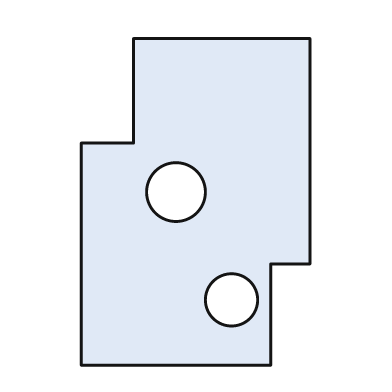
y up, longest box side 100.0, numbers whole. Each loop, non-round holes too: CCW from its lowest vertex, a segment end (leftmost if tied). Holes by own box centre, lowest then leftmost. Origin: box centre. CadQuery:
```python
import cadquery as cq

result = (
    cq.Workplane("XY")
    .moveTo(-35.0, -50.0)
    .lineTo(23.0, -50.0)
    .lineTo(23.0, -19.0)
    .lineTo(35.0, -19.0)
    .lineTo(35.0, 50.0)
    .lineTo(-19.0, 50.0)
    .lineTo(-19.0, 18.0)
    .lineTo(-35.0, 18.0)
    .close()
    .moveTo(11.0, -30.0)
    .circle(8.0)
    .moveTo(-6.0, 3.0)
    .circle(9.0)
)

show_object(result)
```